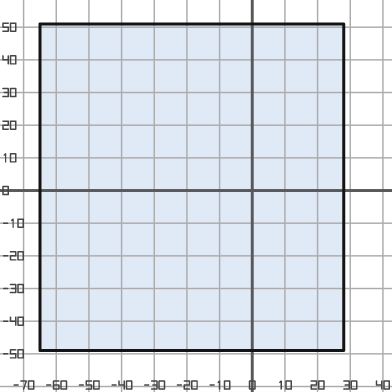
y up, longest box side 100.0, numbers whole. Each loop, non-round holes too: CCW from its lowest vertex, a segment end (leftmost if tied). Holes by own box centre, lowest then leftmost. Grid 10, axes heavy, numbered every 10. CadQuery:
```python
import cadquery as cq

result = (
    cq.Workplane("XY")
    .moveTo(-65.0, -49.0)
    .lineTo(28.0, -49.0)
    .lineTo(28.0, 51.0)
    .lineTo(-65.0, 51.0)
    .close()
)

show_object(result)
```